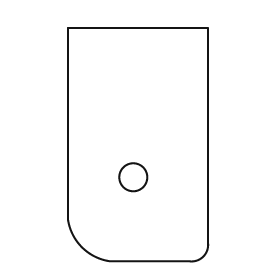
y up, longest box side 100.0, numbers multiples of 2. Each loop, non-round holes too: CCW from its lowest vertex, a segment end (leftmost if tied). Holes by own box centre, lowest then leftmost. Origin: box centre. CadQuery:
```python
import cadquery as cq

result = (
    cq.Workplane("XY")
    .moveTo(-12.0, -50.0)
    .lineTo(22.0, -50.0)
    .threePointArc((28.0, -48.0), (30.0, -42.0))
    .lineTo(30.0, 50.0)
    .lineTo(-30.0, 50.0)
    .lineTo(-30.0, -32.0)
    .threePointArc((-24.0, -44.0), (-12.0, -50.0))
    .close()
    .moveTo(-2.0, -14.0)
    .circle(6.0)
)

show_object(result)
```